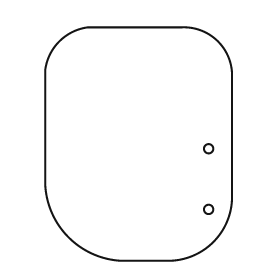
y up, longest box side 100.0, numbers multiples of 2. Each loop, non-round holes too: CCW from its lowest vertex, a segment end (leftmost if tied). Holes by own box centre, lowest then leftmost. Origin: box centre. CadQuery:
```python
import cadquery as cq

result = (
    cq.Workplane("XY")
    .moveTo(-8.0, -50.0)
    .lineTo(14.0, -50.0)
    .threePointArc((32.0, -42.0), (40.0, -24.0))
    .lineTo(40.0, 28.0)
    .threePointArc((34.0, 44.0), (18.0, 50.0))
    .lineTo(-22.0, 50.0)
    .threePointArc((-34.0, 44.0), (-40.0, 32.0))
    .lineTo(-40.0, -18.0)
    .threePointArc((-30.0, -40.0), (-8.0, -50.0))
    .close()
    .moveTo(30.0, -28.0)
    .circle(2.0)
    .moveTo(30.0, -2.0)
    .circle(2.0)
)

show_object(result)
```